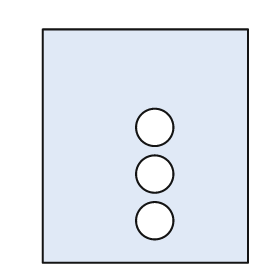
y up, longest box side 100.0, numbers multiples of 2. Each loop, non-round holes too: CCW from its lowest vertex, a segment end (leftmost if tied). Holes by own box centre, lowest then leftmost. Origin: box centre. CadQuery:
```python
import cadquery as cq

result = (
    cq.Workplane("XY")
    .moveTo(-44.0, -50.0)
    .lineTo(44.0, -50.0)
    .lineTo(44.0, 50.0)
    .lineTo(-44.0, 50.0)
    .close()
    .moveTo(4.0, -32.0)
    .circle(8.0)
    .moveTo(4.0, -12.0)
    .circle(8.0)
    .moveTo(4.0, 8.0)
    .circle(8.0)
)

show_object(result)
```